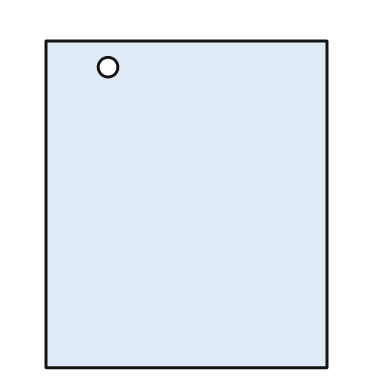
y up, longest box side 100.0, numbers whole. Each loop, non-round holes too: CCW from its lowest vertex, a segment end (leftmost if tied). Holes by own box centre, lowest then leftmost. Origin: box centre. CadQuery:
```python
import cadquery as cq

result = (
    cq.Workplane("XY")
    .moveTo(-43.0, -50.0)
    .lineTo(43.0, -50.0)
    .lineTo(43.0, 50.0)
    .lineTo(-43.0, 50.0)
    .close()
    .moveTo(-24.0, 42.0)
    .circle(3.0)
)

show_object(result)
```